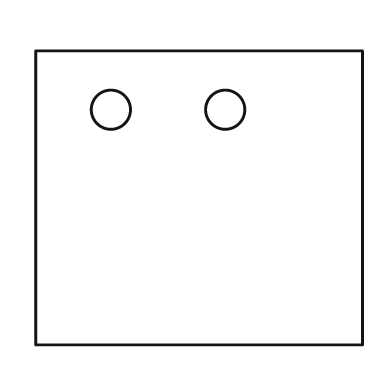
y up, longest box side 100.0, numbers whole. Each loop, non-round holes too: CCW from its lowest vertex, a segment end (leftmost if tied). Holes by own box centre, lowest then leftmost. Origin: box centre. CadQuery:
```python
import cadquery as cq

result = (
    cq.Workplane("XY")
    .moveTo(-50.0, -45.0)
    .lineTo(50.0, -45.0)
    .lineTo(50.0, 45.0)
    .lineTo(-50.0, 45.0)
    .close()
    .moveTo(-27.0, 27.0)
    .circle(6.0)
    .moveTo(8.0, 27.0)
    .circle(6.0)
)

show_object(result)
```